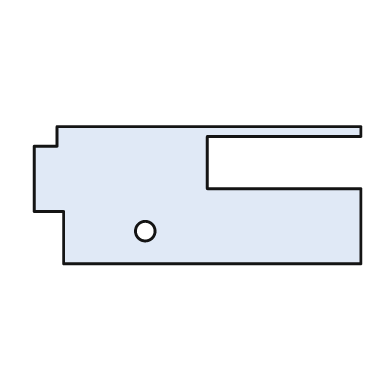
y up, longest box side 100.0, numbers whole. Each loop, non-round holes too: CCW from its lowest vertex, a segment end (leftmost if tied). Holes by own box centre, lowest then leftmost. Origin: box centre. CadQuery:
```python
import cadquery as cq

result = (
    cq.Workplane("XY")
    .moveTo(-41.0, -21.0)
    .lineTo(50.0, -21.0)
    .lineTo(50.0, 2.0)
    .lineTo(3.0, 2.0)
    .lineTo(3.0, 18.0)
    .lineTo(50.0, 18.0)
    .lineTo(50.0, 21.0)
    .lineTo(-43.0, 21.0)
    .lineTo(-43.0, 15.0)
    .lineTo(-50.0, 15.0)
    .lineTo(-50.0, -5.0)
    .lineTo(-41.0, -5.0)
    .close()
    .moveTo(-16.0, -11.0)
    .circle(3.0)
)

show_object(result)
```